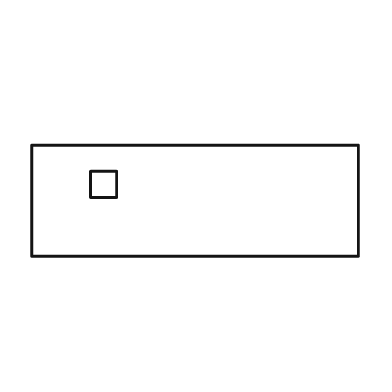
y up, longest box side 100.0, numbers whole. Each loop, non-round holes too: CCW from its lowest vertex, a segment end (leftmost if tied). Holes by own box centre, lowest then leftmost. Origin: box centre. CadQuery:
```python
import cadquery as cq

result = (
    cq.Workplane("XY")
    .moveTo(-50.0, -17.0)
    .lineTo(50.0, -17.0)
    .lineTo(50.0, 17.0)
    .lineTo(-50.0, 17.0)
    .close()
    .moveTo(-32.0, 1.0)
    .lineTo(-24.0, 1.0)
    .lineTo(-24.0, 9.0)
    .lineTo(-32.0, 9.0)
    .close()
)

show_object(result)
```